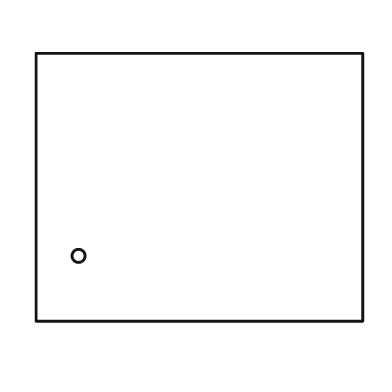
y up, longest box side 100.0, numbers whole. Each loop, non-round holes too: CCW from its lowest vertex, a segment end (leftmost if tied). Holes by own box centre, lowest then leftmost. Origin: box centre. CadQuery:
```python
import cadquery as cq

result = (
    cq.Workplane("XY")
    .moveTo(-50.0, -41.0)
    .lineTo(50.0, -41.0)
    .lineTo(50.0, 41.0)
    .lineTo(-50.0, 41.0)
    .close()
    .moveTo(-37.0, -21.0)
    .circle(2.0)
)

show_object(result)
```